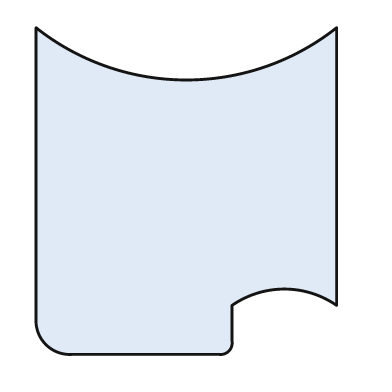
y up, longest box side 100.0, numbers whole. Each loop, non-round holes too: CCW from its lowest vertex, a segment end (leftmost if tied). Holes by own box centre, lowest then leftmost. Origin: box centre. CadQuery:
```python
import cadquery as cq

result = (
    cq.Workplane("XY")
    .moveTo(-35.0, -50.0)
    .lineTo(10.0, -50.0)
    .threePointArc((13.0, -49.0), (14.0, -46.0))
    .lineTo(14.0, -35.0)
    .threePointArc((30.0, -30.0), (46.0, -35.0))
    .lineTo(46.0, 50.0)
    .threePointArc((0.0, 34.0), (-46.0, 50.0))
    .lineTo(-46.0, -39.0)
    .threePointArc((-43.0, -47.0), (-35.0, -50.0))
    .close()
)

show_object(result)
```